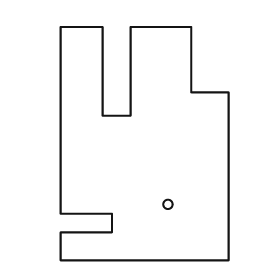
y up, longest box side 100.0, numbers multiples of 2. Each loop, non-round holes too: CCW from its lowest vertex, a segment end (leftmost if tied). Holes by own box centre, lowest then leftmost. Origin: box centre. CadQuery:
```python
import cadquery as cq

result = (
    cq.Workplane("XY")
    .moveTo(-36.0, -50.0)
    .lineTo(36.0, -50.0)
    .lineTo(36.0, 22.0)
    .lineTo(20.0, 22.0)
    .lineTo(20.0, 50.0)
    .lineTo(-6.0, 50.0)
    .lineTo(-6.0, 12.0)
    .lineTo(-18.0, 12.0)
    .lineTo(-18.0, 50.0)
    .lineTo(-36.0, 50.0)
    .lineTo(-36.0, -30.0)
    .lineTo(-14.0, -30.0)
    .lineTo(-14.0, -38.0)
    .lineTo(-36.0, -38.0)
    .close()
    .moveTo(10.0, -26.0)
    .circle(2.0)
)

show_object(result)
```